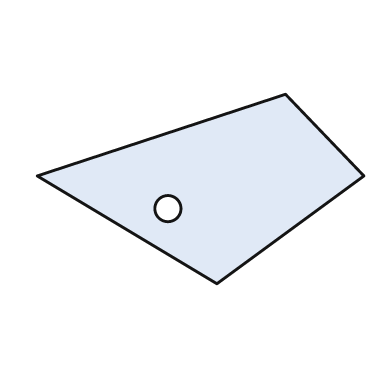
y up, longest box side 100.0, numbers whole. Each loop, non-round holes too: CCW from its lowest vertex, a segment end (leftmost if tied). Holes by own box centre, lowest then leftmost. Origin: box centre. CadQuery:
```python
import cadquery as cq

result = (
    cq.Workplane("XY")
    .moveTo(5.0, -29.0)
    .lineTo(50.0, 4.0)
    .lineTo(26.0, 29.0)
    .lineTo(-50.0, 4.0)
    .close()
    .moveTo(-10.0, -6.0)
    .circle(4.0)
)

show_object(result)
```